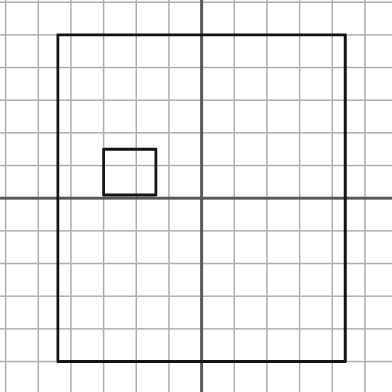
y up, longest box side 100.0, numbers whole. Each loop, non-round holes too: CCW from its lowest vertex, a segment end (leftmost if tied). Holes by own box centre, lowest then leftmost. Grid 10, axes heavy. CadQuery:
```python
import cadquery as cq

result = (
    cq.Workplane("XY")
    .moveTo(-44.0, -50.0)
    .lineTo(44.0, -50.0)
    .lineTo(44.0, 50.0)
    .lineTo(-44.0, 50.0)
    .close()
    .moveTo(-30.0, 1.0)
    .lineTo(-14.0, 1.0)
    .lineTo(-14.0, 15.0)
    .lineTo(-30.0, 15.0)
    .close()
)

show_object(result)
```